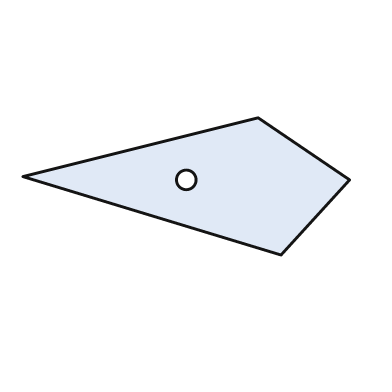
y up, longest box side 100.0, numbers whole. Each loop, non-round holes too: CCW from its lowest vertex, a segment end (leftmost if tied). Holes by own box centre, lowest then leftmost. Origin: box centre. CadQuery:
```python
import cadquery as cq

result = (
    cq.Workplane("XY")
    .moveTo(29.0, -21.0)
    .lineTo(50.0, 2.0)
    .lineTo(22.0, 21.0)
    .lineTo(-50.0, 3.0)
    .close()
    .moveTo(0.0, 2.0)
    .circle(3.0)
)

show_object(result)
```